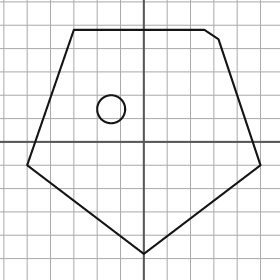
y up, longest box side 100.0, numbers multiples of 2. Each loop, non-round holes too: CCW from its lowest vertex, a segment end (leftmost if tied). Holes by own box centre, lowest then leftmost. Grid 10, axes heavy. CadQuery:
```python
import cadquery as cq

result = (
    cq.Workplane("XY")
    .moveTo(0.0, -48.0)
    .lineTo(50.0, -10.0)
    .lineTo(32.0, 44.0)
    .lineTo(26.0, 48.0)
    .lineTo(-30.0, 48.0)
    .lineTo(-50.0, -10.0)
    .close()
    .moveTo(-14.0, 14.0)
    .circle(6.0)
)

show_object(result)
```